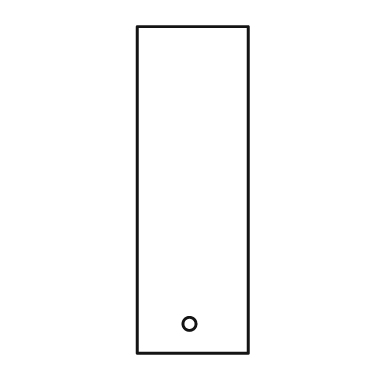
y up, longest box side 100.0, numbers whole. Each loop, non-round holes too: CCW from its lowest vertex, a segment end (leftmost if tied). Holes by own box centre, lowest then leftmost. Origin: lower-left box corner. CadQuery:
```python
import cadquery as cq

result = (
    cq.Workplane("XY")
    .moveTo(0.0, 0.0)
    .lineTo(34.0, 0.0)
    .lineTo(34.0, 100.0)
    .lineTo(0.0, 100.0)
    .close()
    .moveTo(16.0, 9.0)
    .circle(2.0)
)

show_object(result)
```